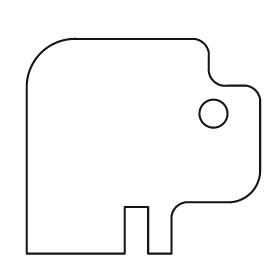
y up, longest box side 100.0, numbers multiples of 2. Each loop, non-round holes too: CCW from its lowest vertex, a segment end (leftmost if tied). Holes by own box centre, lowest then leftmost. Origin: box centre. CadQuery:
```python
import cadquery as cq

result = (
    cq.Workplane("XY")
    .moveTo(-50.0, -46.0)
    .lineTo(-8.0, -46.0)
    .lineTo(-8.0, -26.0)
    .lineTo(2.0, -26.0)
    .lineTo(2.0, -46.0)
    .lineTo(12.0, -46.0)
    .lineTo(12.0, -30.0)
    .threePointArc((14.0, -26.0), (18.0, -24.0))
    .lineTo(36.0, -24.0)
    .threePointArc((46.0, -20.0), (50.0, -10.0))
    .lineTo(50.0, 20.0)
    .threePointArc((48.0, 24.0), (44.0, 26.0))
    .lineTo(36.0, 26.0)
    .threePointArc((30.0, 28.0), (28.0, 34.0))
    .lineTo(28.0, 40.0)
    .threePointArc((26.0, 44.0), (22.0, 46.0))
    .lineTo(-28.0, 46.0)
    .threePointArc((-44.0, 40.0), (-50.0, 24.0))
    .close()
    .moveTo(30.0, 14.0)
    .circle(6.0)
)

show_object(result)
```